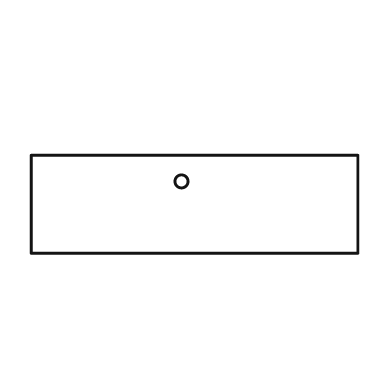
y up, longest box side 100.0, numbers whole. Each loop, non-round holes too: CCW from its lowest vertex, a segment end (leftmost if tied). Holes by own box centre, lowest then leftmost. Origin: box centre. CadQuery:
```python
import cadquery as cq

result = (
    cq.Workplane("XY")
    .moveTo(-50.0, -15.0)
    .lineTo(50.0, -15.0)
    .lineTo(50.0, 15.0)
    .lineTo(-50.0, 15.0)
    .close()
    .moveTo(-4.0, 7.0)
    .circle(2.0)
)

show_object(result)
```